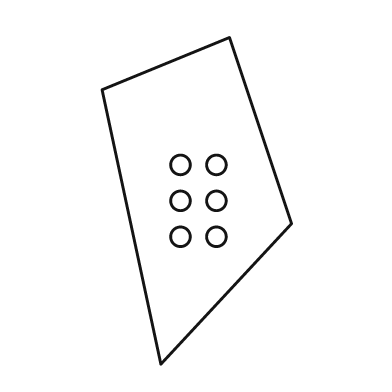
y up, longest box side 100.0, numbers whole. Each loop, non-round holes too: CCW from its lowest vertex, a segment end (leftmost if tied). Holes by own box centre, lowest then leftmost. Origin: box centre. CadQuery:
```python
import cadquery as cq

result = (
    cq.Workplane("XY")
    .moveTo(-11.0, -50.0)
    .lineTo(29.0, -7.0)
    .lineTo(10.0, 50.0)
    .lineTo(-29.0, 34.0)
    .close()
    .moveTo(-5.0, -11.0)
    .circle(3.0)
    .moveTo(6.0, -11.0)
    .circle(3.0)
    .moveTo(-5.0, 0.0)
    .circle(3.0)
    .moveTo(6.0, 0.0)
    .circle(3.0)
    .moveTo(-5.0, 11.0)
    .circle(3.0)
    .moveTo(6.0, 11.0)
    .circle(3.0)
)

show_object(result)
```